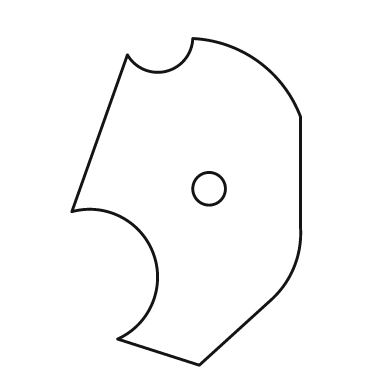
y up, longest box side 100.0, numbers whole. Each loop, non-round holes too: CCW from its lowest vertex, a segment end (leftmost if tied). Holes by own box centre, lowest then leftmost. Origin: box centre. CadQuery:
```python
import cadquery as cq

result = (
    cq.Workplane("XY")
    .moveTo(4.0, -50.0)
    .lineTo(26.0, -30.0)
    .threePointArc((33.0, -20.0), (35.0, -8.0))
    .lineTo(35.0, 26.0)
    .threePointArc((22.0, 43.0), (2.0, 50.0))
    .threePointArc((-6.0, 40.0), (-18.0, 45.0))
    .lineTo(-35.0, -3.0)
    .threePointArc((-10.0, -16.0), (-21.0, -42.0))
    .close()
    .moveTo(7.0, 4.0)
    .circle(5.0)
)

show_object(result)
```